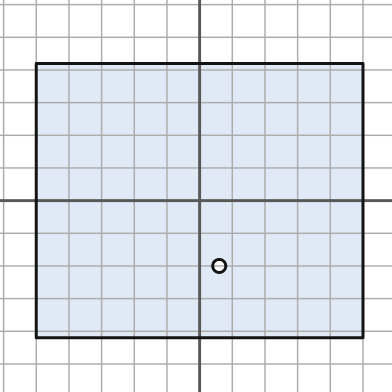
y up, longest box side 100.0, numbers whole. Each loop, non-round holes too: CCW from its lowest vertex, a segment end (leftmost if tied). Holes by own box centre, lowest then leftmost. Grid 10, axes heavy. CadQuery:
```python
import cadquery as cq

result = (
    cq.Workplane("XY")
    .moveTo(-50.0, -42.0)
    .lineTo(50.0, -42.0)
    .lineTo(50.0, 42.0)
    .lineTo(-50.0, 42.0)
    .close()
    .moveTo(6.0, -20.0)
    .circle(2.0)
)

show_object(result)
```